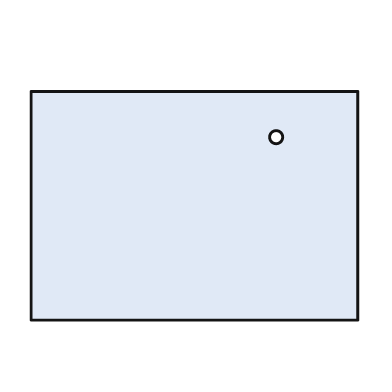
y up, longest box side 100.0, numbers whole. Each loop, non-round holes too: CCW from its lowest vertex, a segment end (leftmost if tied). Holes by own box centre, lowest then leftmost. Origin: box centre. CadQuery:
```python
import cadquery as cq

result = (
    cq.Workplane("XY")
    .moveTo(-50.0, -35.0)
    .lineTo(50.0, -35.0)
    .lineTo(50.0, 35.0)
    .lineTo(-50.0, 35.0)
    .close()
    .moveTo(25.0, 21.0)
    .circle(2.0)
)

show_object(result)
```